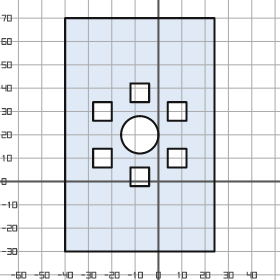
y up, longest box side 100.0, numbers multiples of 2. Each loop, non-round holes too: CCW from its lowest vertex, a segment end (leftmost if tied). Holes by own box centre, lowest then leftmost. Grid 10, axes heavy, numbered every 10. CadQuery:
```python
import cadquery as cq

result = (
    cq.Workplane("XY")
    .moveTo(-40.0, -30.0)
    .lineTo(24.0, -30.0)
    .lineTo(24.0, 70.0)
    .lineTo(-40.0, 70.0)
    .close()
    .moveTo(-12.0, -2.0)
    .lineTo(-4.0, -2.0)
    .lineTo(-4.0, 6.0)
    .lineTo(-12.0, 6.0)
    .close()
    .moveTo(-28.0, 6.0)
    .lineTo(-20.0, 6.0)
    .lineTo(-20.0, 14.0)
    .lineTo(-28.0, 14.0)
    .close()
    .moveTo(4.0, 6.0)
    .lineTo(12.0, 6.0)
    .lineTo(12.0, 14.0)
    .lineTo(4.0, 14.0)
    .close()
    .moveTo(-8.0, 20.0)
    .circle(8.0)
    .moveTo(-28.0, 26.0)
    .lineTo(-20.0, 26.0)
    .lineTo(-20.0, 34.0)
    .lineTo(-28.0, 34.0)
    .close()
    .moveTo(4.0, 26.0)
    .lineTo(12.0, 26.0)
    .lineTo(12.0, 34.0)
    .lineTo(4.0, 34.0)
    .close()
    .moveTo(-12.0, 34.0)
    .lineTo(-4.0, 34.0)
    .lineTo(-4.0, 42.0)
    .lineTo(-12.0, 42.0)
    .close()
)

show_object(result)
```